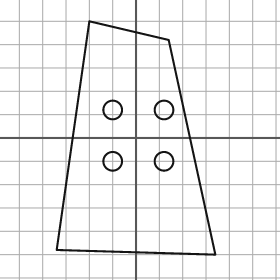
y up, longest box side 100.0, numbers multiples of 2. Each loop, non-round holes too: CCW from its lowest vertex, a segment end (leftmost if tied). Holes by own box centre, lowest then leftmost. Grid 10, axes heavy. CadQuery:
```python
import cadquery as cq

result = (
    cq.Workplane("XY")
    .moveTo(34.0, -50.0)
    .lineTo(14.0, 42.0)
    .lineTo(-20.0, 50.0)
    .lineTo(-34.0, -48.0)
    .close()
    .moveTo(-10.0, -10.0)
    .circle(4.0)
    .moveTo(12.0, -10.0)
    .circle(4.0)
    .moveTo(-10.0, 12.0)
    .circle(4.0)
    .moveTo(12.0, 12.0)
    .circle(4.0)
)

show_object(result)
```